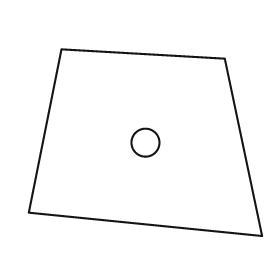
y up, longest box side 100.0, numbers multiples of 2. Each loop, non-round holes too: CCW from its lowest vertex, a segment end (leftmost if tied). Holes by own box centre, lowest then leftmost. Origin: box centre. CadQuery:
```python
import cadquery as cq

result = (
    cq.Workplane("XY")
    .moveTo(50.0, -40.0)
    .lineTo(34.0, 36.0)
    .lineTo(-36.0, 40.0)
    .lineTo(-50.0, -30.0)
    .close()
    .moveTo(0.0, 0.0)
    .circle(6.0)
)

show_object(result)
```